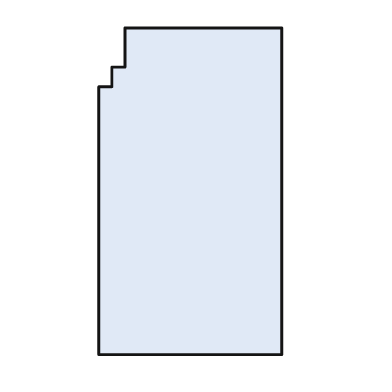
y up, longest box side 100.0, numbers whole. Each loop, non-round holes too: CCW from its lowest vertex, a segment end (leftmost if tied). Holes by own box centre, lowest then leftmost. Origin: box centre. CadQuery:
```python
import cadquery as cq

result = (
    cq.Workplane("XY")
    .moveTo(-28.0, -50.0)
    .lineTo(28.0, -50.0)
    .lineTo(28.0, 50.0)
    .lineTo(-20.0, 50.0)
    .lineTo(-20.0, 38.0)
    .lineTo(-24.0, 38.0)
    .lineTo(-24.0, 32.0)
    .lineTo(-28.0, 32.0)
    .close()
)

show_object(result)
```